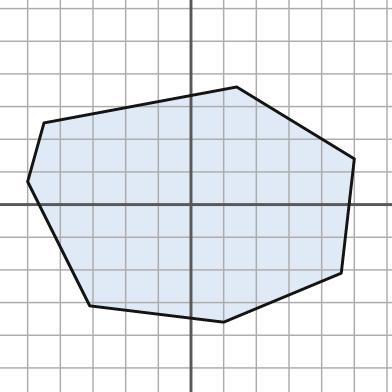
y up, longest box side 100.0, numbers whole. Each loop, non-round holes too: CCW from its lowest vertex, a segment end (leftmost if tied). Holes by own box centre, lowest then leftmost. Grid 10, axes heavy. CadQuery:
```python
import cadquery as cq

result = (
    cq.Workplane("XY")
    .moveTo(10.0, -36.0)
    .lineTo(46.0, -21.0)
    .lineTo(50.0, 14.0)
    .lineTo(14.0, 36.0)
    .lineTo(-45.0, 25.0)
    .lineTo(-50.0, 7.0)
    .lineTo(-31.0, -31.0)
    .close()
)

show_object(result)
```